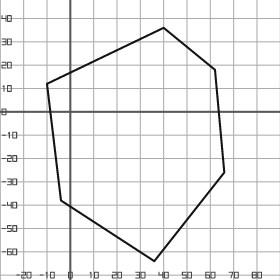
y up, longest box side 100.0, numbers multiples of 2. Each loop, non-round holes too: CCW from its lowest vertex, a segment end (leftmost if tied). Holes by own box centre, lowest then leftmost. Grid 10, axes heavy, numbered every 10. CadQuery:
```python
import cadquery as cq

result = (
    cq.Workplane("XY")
    .moveTo(36.0, -64.0)
    .lineTo(66.0, -26.0)
    .lineTo(62.0, 18.0)
    .lineTo(40.0, 36.0)
    .lineTo(-10.0, 12.0)
    .lineTo(-4.0, -38.0)
    .close()
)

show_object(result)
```